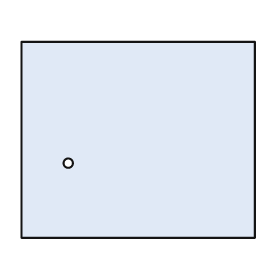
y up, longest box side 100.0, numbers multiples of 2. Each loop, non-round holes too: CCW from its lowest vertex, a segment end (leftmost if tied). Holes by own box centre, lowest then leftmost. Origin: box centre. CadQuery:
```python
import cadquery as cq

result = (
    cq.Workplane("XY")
    .moveTo(-50.0, -42.0)
    .lineTo(50.0, -42.0)
    .lineTo(50.0, 42.0)
    .lineTo(-50.0, 42.0)
    .close()
    .moveTo(-30.0, -10.0)
    .circle(2.0)
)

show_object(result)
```